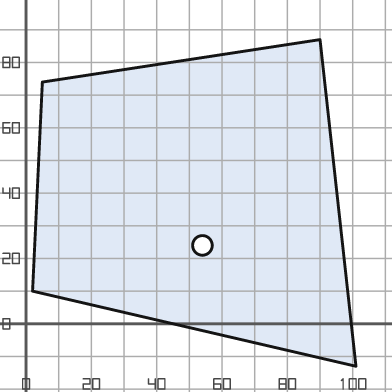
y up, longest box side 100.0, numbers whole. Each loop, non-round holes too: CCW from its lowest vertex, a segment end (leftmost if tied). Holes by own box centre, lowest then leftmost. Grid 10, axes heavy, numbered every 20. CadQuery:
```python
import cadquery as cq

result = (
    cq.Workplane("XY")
    .moveTo(101.0, -13.0)
    .lineTo(90.0, 87.0)
    .lineTo(5.0, 74.0)
    .lineTo(2.0, 10.0)
    .close()
    .moveTo(54.0, 24.0)
    .circle(3.0)
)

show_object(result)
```